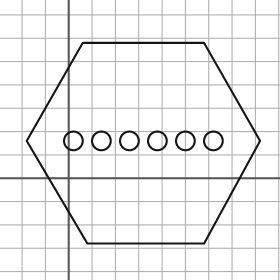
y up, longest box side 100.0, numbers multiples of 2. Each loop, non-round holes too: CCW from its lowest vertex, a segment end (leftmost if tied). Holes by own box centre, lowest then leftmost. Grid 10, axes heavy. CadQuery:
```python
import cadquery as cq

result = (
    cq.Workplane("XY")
    .moveTo(8.0, -28.0)
    .lineTo(58.0, -28.0)
    .lineTo(82.0, 16.0)
    .lineTo(58.0, 58.0)
    .lineTo(6.0, 58.0)
    .lineTo(-18.0, 16.0)
    .close()
    .moveTo(2.0, 16.0)
    .circle(4.0)
    .moveTo(14.0, 16.0)
    .circle(4.0)
    .moveTo(26.0, 16.0)
    .circle(4.0)
    .moveTo(38.0, 16.0)
    .circle(4.0)
    .moveTo(50.0, 16.0)
    .circle(4.0)
    .moveTo(62.0, 16.0)
    .circle(4.0)
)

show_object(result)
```